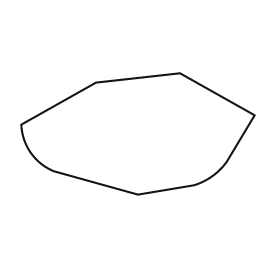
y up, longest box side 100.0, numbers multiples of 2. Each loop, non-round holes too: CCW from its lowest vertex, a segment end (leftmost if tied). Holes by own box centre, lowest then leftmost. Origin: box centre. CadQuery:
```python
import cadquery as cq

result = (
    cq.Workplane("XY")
    .moveTo(0.0, -26.0)
    .lineTo(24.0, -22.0)
    .threePointArc((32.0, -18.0), (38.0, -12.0))
    .lineTo(50.0, 8.0)
    .lineTo(18.0, 26.0)
    .lineTo(-18.0, 22.0)
    .lineTo(-50.0, 4.0)
    .threePointArc((-46.0, -8.0), (-36.0, -16.0))
    .close()
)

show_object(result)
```